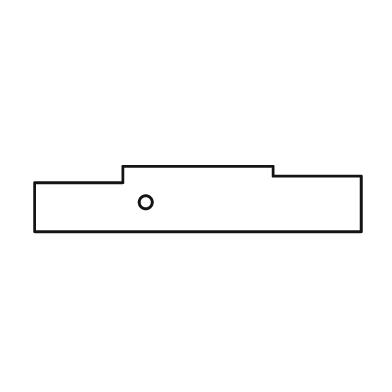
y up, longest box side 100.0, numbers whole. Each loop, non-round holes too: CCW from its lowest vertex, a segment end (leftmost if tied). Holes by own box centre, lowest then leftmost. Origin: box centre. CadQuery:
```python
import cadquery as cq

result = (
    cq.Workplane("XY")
    .moveTo(-50.0, -10.0)
    .lineTo(50.0, -10.0)
    .lineTo(50.0, 7.0)
    .lineTo(23.0, 7.0)
    .lineTo(23.0, 10.0)
    .lineTo(-23.0, 10.0)
    .lineTo(-23.0, 5.0)
    .lineTo(-50.0, 5.0)
    .close()
    .moveTo(-16.0, -1.0)
    .circle(2.0)
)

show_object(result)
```